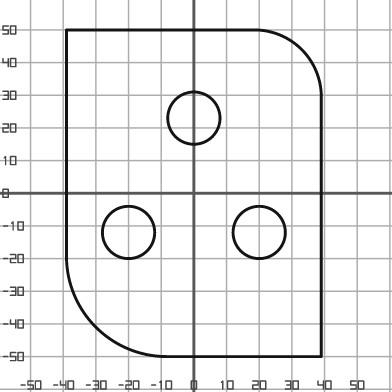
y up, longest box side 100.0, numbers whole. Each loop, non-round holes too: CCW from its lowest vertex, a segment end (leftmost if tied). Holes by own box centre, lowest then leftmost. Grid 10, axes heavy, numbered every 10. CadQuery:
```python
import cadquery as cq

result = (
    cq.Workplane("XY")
    .moveTo(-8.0, -50.0)
    .lineTo(39.0, -50.0)
    .lineTo(39.0, 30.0)
    .threePointArc((33.0, 44.0), (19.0, 50.0))
    .lineTo(-39.0, 50.0)
    .lineTo(-39.0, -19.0)
    .threePointArc((-30.0, -41.0), (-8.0, -50.0))
    .close()
    .moveTo(-20.0, -12.0)
    .circle(8.0)
    .moveTo(20.0, -12.0)
    .circle(8.0)
    .moveTo(0.0, 23.0)
    .circle(8.0)
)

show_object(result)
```